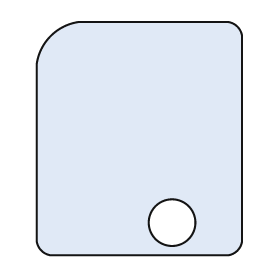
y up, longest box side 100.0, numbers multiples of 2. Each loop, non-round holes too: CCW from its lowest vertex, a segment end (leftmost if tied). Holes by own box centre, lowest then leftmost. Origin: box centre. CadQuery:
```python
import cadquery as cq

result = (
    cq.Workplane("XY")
    .moveTo(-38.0, -50.0)
    .lineTo(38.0, -50.0)
    .threePointArc((42.0, -48.0), (44.0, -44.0))
    .lineTo(44.0, 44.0)
    .threePointArc((42.0, 48.0), (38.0, 50.0))
    .lineTo(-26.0, 50.0)
    .threePointArc((-38.0, 44.0), (-44.0, 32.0))
    .lineTo(-44.0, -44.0)
    .threePointArc((-42.0, -48.0), (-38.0, -50.0))
    .close()
    .moveTo(14.0, -36.0)
    .circle(10.0)
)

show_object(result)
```